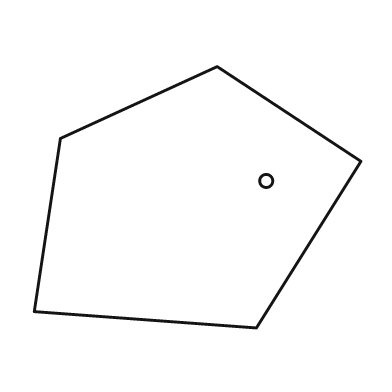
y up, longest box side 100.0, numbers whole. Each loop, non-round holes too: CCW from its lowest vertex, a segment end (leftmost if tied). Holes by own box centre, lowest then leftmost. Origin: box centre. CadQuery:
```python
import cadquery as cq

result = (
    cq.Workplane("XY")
    .moveTo(18.0, -40.0)
    .lineTo(50.0, 11.0)
    .lineTo(6.0, 40.0)
    .lineTo(-42.0, 18.0)
    .lineTo(-50.0, -35.0)
    .close()
    .moveTo(21.0, 5.0)
    .circle(2.0)
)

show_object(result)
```